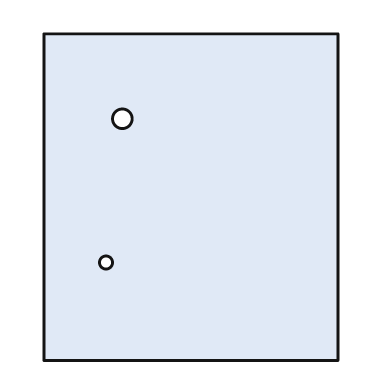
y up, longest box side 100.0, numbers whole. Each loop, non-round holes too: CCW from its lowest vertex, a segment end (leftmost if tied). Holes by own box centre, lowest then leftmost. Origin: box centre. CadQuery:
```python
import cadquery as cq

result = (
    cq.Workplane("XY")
    .moveTo(-45.0, -50.0)
    .lineTo(45.0, -50.0)
    .lineTo(45.0, 50.0)
    .lineTo(-45.0, 50.0)
    .close()
    .moveTo(-26.0, -20.0)
    .circle(2.0)
    .moveTo(-21.0, 24.0)
    .circle(3.0)
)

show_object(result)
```